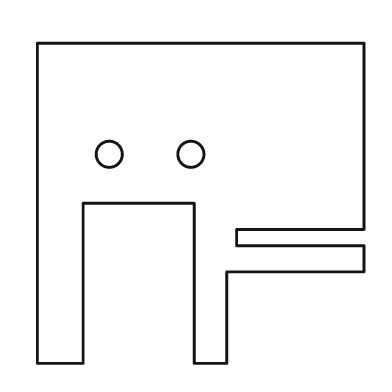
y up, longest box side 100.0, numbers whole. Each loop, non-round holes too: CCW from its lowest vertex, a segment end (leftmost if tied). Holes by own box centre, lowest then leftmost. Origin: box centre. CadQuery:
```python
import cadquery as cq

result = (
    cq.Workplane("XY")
    .moveTo(-50.0, -49.0)
    .lineTo(-36.0, -49.0)
    .lineTo(-36.0, 0.0)
    .lineTo(-2.0, 0.0)
    .lineTo(-2.0, -49.0)
    .lineTo(8.0, -49.0)
    .lineTo(8.0, -21.0)
    .lineTo(50.0, -21.0)
    .lineTo(50.0, -13.0)
    .lineTo(11.0, -13.0)
    .lineTo(11.0, -8.0)
    .lineTo(50.0, -8.0)
    .lineTo(50.0, 49.0)
    .lineTo(-50.0, 49.0)
    .close()
    .moveTo(-28.0, 15.0)
    .circle(4.0)
    .moveTo(-3.0, 15.0)
    .circle(4.0)
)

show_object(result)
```